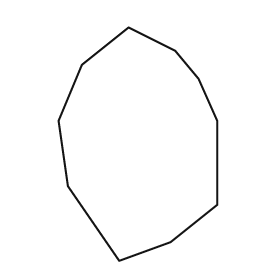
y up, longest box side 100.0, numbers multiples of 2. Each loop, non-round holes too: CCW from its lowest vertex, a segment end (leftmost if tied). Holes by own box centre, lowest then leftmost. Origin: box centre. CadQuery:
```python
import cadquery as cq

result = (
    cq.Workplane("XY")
    .moveTo(-8.0, -50.0)
    .lineTo(14.0, -42.0)
    .lineTo(34.0, -26.0)
    .lineTo(34.0, 10.0)
    .lineTo(26.0, 28.0)
    .lineTo(16.0, 40.0)
    .lineTo(-4.0, 50.0)
    .lineTo(-24.0, 34.0)
    .lineTo(-34.0, 10.0)
    .lineTo(-30.0, -18.0)
    .close()
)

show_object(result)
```